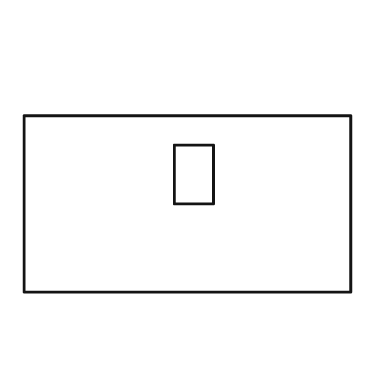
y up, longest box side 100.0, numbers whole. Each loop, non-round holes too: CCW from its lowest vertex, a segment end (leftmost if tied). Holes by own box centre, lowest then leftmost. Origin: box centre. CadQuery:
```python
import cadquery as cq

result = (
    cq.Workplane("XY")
    .moveTo(-50.0, -27.0)
    .lineTo(50.0, -27.0)
    .lineTo(50.0, 27.0)
    .lineTo(-50.0, 27.0)
    .close()
    .moveTo(-4.0, 0.0)
    .lineTo(8.0, 0.0)
    .lineTo(8.0, 18.0)
    .lineTo(-4.0, 18.0)
    .close()
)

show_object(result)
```